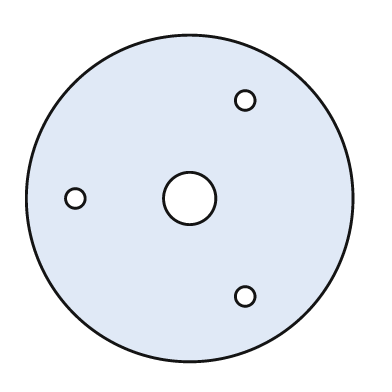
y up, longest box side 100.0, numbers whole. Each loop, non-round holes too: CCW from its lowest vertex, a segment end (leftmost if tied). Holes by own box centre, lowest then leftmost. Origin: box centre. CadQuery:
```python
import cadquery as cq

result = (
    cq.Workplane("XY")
    .moveTo(0.0, 0.0)
    .circle(50.0)
    .moveTo(17.0, -30.0)
    .circle(3.0)
    .moveTo(-35.0, 0.0)
    .circle(3.0)
    .moveTo(0.0, 0.0)
    .circle(8.0)
    .moveTo(17.0, 30.0)
    .circle(3.0)
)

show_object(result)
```